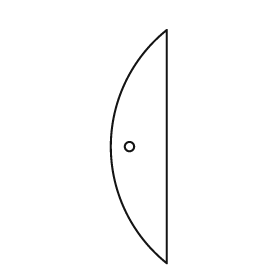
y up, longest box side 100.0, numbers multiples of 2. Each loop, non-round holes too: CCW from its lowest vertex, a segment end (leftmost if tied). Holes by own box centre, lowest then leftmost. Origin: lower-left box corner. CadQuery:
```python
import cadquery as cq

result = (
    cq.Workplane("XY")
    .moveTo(24.0, 0.0)
    .lineTo(24.0, 100.0)
    .threePointArc((0.0, 50.0), (24.0, 0.0))
    .close()
    .moveTo(8.0, 50.0)
    .circle(2.0)
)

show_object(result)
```